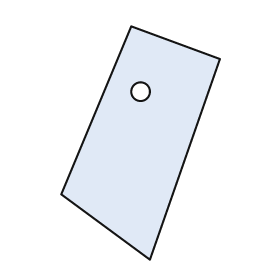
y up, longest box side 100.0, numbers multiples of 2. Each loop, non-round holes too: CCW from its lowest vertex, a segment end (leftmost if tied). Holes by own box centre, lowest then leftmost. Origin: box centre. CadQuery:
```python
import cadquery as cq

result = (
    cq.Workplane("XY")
    .moveTo(4.0, -50.0)
    .lineTo(34.0, 36.0)
    .lineTo(-4.0, 50.0)
    .lineTo(-34.0, -22.0)
    .close()
    .moveTo(0.0, 22.0)
    .circle(4.0)
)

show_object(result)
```